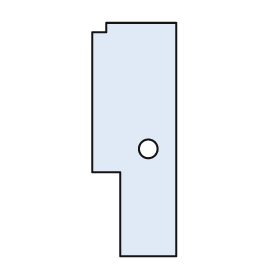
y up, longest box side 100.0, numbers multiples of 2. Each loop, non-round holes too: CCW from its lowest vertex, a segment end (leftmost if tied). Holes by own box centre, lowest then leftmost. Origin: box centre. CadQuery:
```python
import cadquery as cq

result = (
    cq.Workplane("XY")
    .moveTo(-6.0, -50.0)
    .lineTo(18.0, -50.0)
    .lineTo(18.0, 50.0)
    .lineTo(-12.0, 50.0)
    .lineTo(-12.0, 46.0)
    .lineTo(-18.0, 46.0)
    .lineTo(-18.0, -14.0)
    .lineTo(-6.0, -14.0)
    .close()
    .moveTo(6.0, -4.0)
    .circle(4.0)
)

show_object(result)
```